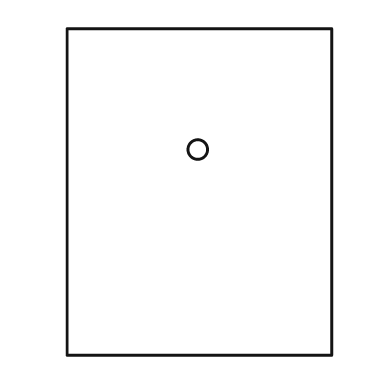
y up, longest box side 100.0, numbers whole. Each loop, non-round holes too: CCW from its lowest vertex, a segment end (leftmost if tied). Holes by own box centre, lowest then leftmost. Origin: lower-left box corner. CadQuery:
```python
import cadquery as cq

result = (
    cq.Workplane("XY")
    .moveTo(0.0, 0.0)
    .lineTo(81.0, 0.0)
    .lineTo(81.0, 100.0)
    .lineTo(0.0, 100.0)
    .close()
    .moveTo(40.0, 63.0)
    .circle(3.0)
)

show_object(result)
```